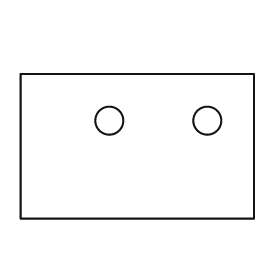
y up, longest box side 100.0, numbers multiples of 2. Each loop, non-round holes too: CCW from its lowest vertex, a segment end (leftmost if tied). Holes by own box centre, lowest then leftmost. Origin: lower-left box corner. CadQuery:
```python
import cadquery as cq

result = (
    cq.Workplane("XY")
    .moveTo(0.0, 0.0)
    .lineTo(100.0, 0.0)
    .lineTo(100.0, 62.0)
    .lineTo(0.0, 62.0)
    .close()
    .moveTo(38.0, 42.0)
    .circle(6.0)
    .moveTo(80.0, 42.0)
    .circle(6.0)
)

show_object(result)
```